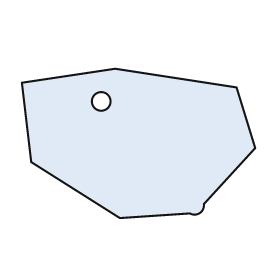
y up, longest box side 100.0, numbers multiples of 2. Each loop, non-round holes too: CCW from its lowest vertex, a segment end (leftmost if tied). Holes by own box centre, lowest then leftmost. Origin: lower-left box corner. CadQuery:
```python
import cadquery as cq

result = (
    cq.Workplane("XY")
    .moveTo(42.0, 0.0)
    .lineTo(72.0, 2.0)
    .threePointArc((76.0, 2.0), (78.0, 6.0))
    .lineTo(100.0, 30.0)
    .lineTo(92.0, 56.0)
    .lineTo(40.0, 64.0)
    .lineTo(0.0, 58.0)
    .lineTo(4.0, 24.0)
    .close()
    .moveTo(34.0, 50.0)
    .circle(4.0)
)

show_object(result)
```